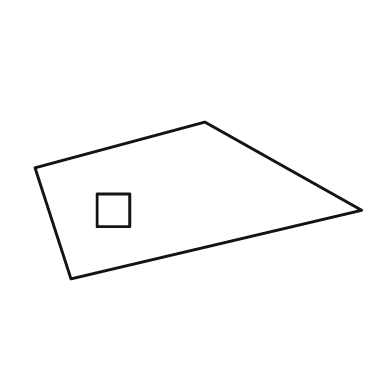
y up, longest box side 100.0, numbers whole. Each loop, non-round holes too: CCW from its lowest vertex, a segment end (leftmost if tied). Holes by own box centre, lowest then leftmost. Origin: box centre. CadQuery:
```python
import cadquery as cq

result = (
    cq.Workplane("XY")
    .moveTo(-39.0, -24.0)
    .lineTo(50.0, -3.0)
    .lineTo(2.0, 24.0)
    .lineTo(-50.0, 10.0)
    .close()
    .moveTo(-31.0, -8.0)
    .lineTo(-21.0, -8.0)
    .lineTo(-21.0, 2.0)
    .lineTo(-31.0, 2.0)
    .close()
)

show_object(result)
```